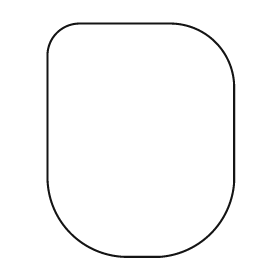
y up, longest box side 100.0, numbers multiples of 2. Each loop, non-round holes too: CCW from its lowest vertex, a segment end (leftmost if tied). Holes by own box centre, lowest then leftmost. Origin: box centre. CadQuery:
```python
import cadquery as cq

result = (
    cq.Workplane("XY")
    .moveTo(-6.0, -50.0)
    .lineTo(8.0, -50.0)
    .threePointArc((30.0, -40.0), (40.0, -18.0))
    .lineTo(40.0, 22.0)
    .threePointArc((32.0, 42.0), (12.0, 50.0))
    .lineTo(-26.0, 50.0)
    .threePointArc((-36.0, 46.0), (-40.0, 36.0))
    .lineTo(-40.0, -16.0)
    .threePointArc((-30.0, -40.0), (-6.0, -50.0))
    .close()
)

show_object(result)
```